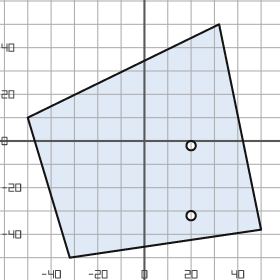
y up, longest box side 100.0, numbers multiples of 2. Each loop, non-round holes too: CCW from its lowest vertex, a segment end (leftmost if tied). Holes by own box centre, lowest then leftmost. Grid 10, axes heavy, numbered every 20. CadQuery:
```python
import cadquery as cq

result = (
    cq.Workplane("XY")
    .moveTo(-32.0, -50.0)
    .lineTo(50.0, -38.0)
    .lineTo(32.0, 50.0)
    .lineTo(-50.0, 10.0)
    .close()
    .moveTo(20.0, -32.0)
    .circle(2.0)
    .moveTo(20.0, -2.0)
    .circle(2.0)
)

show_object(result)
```